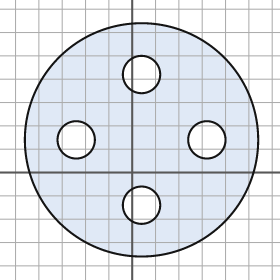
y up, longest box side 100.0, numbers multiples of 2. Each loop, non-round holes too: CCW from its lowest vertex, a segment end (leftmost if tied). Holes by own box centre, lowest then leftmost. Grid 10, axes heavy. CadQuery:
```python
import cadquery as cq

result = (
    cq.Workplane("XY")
    .moveTo(4.0, 14.0)
    .circle(50.0)
    .moveTo(4.0, -14.0)
    .circle(8.0)
    .moveTo(-24.0, 14.0)
    .circle(8.0)
    .moveTo(32.0, 14.0)
    .circle(8.0)
    .moveTo(4.0, 42.0)
    .circle(8.0)
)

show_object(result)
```